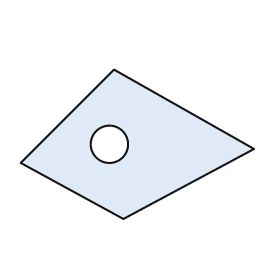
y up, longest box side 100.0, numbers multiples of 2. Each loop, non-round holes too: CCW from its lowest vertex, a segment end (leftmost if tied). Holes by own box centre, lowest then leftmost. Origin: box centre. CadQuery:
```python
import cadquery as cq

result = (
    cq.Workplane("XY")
    .moveTo(-6.0, -32.0)
    .lineTo(50.0, -2.0)
    .lineTo(-10.0, 32.0)
    .lineTo(-50.0, -8.0)
    .close()
    .moveTo(-12.0, 0.0)
    .circle(8.0)
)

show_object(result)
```